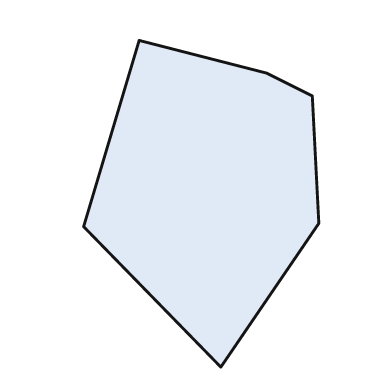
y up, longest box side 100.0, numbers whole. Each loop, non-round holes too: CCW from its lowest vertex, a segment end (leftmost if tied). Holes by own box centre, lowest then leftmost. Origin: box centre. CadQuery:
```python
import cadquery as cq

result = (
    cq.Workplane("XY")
    .moveTo(6.0, -50.0)
    .lineTo(36.0, -6.0)
    .lineTo(34.0, 33.0)
    .lineTo(20.0, 40.0)
    .lineTo(-19.0, 50.0)
    .lineTo(-36.0, -7.0)
    .close()
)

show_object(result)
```